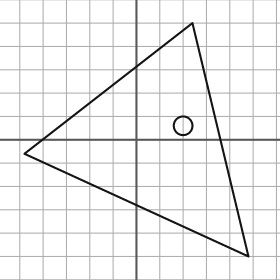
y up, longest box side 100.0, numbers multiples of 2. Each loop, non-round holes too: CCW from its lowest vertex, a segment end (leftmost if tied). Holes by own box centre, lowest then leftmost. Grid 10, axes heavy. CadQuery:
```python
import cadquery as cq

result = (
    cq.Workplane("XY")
    .moveTo(48.0, -50.0)
    .lineTo(24.0, 50.0)
    .lineTo(-48.0, -6.0)
    .close()
    .moveTo(20.0, 6.0)
    .circle(4.0)
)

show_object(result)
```